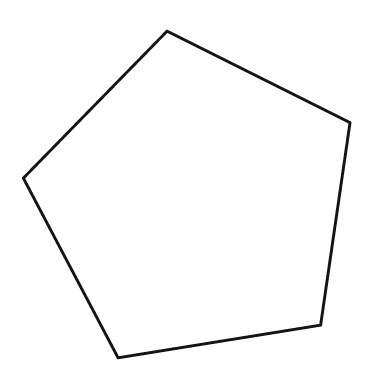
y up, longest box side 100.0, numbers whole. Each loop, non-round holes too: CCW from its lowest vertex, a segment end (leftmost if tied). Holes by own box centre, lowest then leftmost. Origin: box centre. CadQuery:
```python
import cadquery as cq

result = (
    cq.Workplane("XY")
    .moveTo(-21.0, -50.0)
    .lineTo(41.0, -40.0)
    .lineTo(50.0, 22.0)
    .lineTo(-6.0, 50.0)
    .lineTo(-50.0, 5.0)
    .close()
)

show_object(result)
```